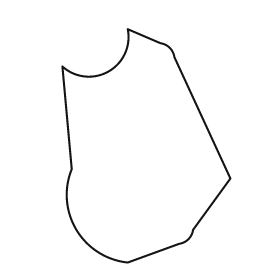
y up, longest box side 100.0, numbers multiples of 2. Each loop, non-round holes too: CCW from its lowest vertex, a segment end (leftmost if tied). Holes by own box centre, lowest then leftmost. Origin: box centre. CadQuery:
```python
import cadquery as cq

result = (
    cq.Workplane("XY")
    .moveTo(-8.0, -50.0)
    .lineTo(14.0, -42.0)
    .threePointArc((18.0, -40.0), (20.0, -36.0))
    .lineTo(36.0, -14.0)
    .lineTo(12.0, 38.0)
    .threePointArc((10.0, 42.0), (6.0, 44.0))
    .lineTo(-8.0, 50.0)
    .threePointArc((-16.0, 32.0), (-36.0, 34.0))
    .lineTo(-32.0, -10.0)
    .threePointArc((-30.0, -36.0), (-8.0, -50.0))
    .close()
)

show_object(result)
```